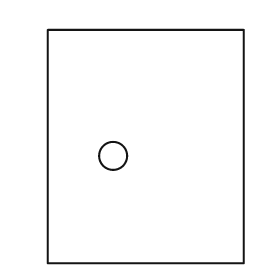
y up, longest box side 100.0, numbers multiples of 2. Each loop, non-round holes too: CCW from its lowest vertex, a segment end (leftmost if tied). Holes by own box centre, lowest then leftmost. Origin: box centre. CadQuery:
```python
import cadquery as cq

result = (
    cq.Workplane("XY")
    .moveTo(-42.0, -50.0)
    .lineTo(42.0, -50.0)
    .lineTo(42.0, 50.0)
    .lineTo(-42.0, 50.0)
    .close()
    .moveTo(-14.0, -4.0)
    .circle(6.0)
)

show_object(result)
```